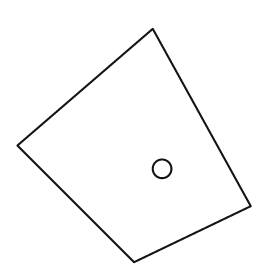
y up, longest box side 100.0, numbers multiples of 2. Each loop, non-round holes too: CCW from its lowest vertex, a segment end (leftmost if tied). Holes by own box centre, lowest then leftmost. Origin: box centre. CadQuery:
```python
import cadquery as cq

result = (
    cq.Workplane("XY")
    .moveTo(0.0, -50.0)
    .lineTo(50.0, -26.0)
    .lineTo(8.0, 50.0)
    .lineTo(-50.0, 0.0)
    .close()
    .moveTo(12.0, -10.0)
    .circle(4.0)
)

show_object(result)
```